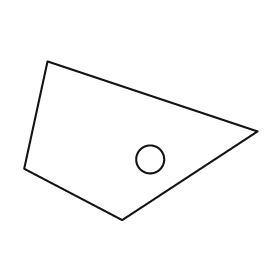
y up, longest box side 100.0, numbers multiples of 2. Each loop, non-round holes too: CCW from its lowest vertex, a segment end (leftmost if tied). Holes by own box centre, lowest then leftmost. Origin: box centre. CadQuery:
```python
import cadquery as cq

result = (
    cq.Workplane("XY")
    .moveTo(-8.0, -34.0)
    .lineTo(50.0, 4.0)
    .lineTo(-40.0, 34.0)
    .lineTo(-50.0, -12.0)
    .close()
    .moveTo(4.0, -8.0)
    .circle(6.0)
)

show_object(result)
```